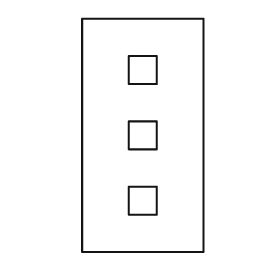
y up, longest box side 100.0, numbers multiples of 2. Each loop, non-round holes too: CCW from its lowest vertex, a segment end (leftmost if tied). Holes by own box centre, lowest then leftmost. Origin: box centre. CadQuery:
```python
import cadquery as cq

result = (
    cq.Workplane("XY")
    .moveTo(-26.0, -50.0)
    .lineTo(26.0, -50.0)
    .lineTo(26.0, 50.0)
    .lineTo(-26.0, 50.0)
    .close()
    .moveTo(-6.0, -34.0)
    .lineTo(6.0, -34.0)
    .lineTo(6.0, -22.0)
    .lineTo(-6.0, -22.0)
    .close()
    .moveTo(-6.0, -6.0)
    .lineTo(6.0, -6.0)
    .lineTo(6.0, 6.0)
    .lineTo(-6.0, 6.0)
    .close()
    .moveTo(-6.0, 22.0)
    .lineTo(6.0, 22.0)
    .lineTo(6.0, 34.0)
    .lineTo(-6.0, 34.0)
    .close()
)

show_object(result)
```